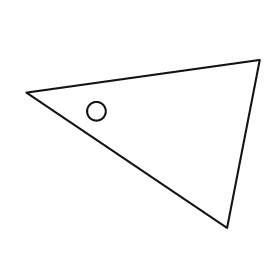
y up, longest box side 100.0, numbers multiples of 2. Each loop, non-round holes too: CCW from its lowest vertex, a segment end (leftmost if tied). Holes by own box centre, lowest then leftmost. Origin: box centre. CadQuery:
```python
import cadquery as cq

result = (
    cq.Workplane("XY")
    .moveTo(36.0, -36.0)
    .lineTo(50.0, 36.0)
    .lineTo(-50.0, 22.0)
    .close()
    .moveTo(-20.0, 14.0)
    .circle(4.0)
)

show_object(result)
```